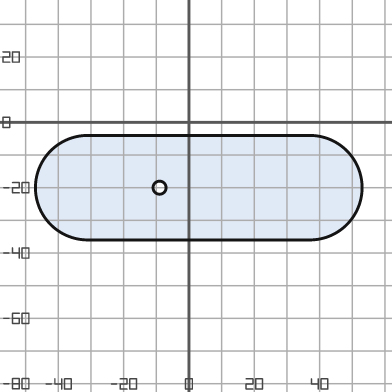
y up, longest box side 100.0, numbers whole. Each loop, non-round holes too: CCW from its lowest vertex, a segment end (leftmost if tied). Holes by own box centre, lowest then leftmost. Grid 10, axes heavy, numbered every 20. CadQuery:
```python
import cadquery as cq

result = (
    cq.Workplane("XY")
    .moveTo(-31.0, -36.0)
    .lineTo(37.0, -36.0)
    .threePointArc((53.0, -20.0), (37.0, -4.0))
    .lineTo(-31.0, -4.0)
    .threePointArc((-47.0, -20.0), (-31.0, -36.0))
    .close()
    .moveTo(-9.0, -20.0)
    .circle(2.0)
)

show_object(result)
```